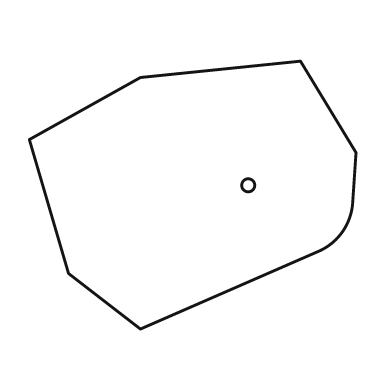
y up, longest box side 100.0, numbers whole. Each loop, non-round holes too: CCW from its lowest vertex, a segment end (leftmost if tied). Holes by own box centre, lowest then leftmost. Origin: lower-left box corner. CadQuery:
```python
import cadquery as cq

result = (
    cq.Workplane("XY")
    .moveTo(34.0, 0.0)
    .lineTo(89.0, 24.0)
    .threePointArc((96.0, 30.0), (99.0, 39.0))
    .lineTo(100.0, 54.0)
    .lineTo(83.0, 82.0)
    .lineTo(34.0, 77.0)
    .lineTo(0.0, 58.0)
    .lineTo(12.0, 17.0)
    .close()
    .moveTo(67.0, 44.0)
    .circle(2.0)
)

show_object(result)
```